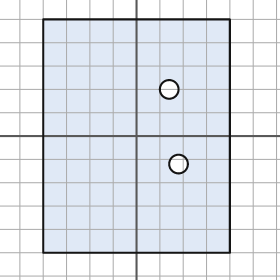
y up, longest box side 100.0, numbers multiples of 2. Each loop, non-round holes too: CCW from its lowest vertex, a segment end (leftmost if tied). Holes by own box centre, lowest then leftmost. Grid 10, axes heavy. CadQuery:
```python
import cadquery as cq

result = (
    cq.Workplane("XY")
    .moveTo(-40.0, -50.0)
    .lineTo(40.0, -50.0)
    .lineTo(40.0, 50.0)
    .lineTo(-40.0, 50.0)
    .close()
    .moveTo(18.0, -12.0)
    .circle(4.0)
    .moveTo(14.0, 20.0)
    .circle(4.0)
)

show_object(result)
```